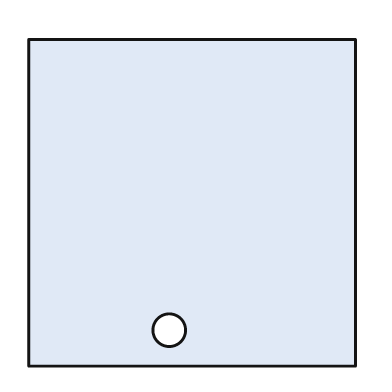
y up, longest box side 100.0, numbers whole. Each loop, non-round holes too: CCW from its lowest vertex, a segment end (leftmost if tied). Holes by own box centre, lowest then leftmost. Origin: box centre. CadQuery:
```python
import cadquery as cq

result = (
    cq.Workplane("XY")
    .moveTo(-50.0, -50.0)
    .lineTo(50.0, -50.0)
    .lineTo(50.0, 50.0)
    .lineTo(-50.0, 50.0)
    .close()
    .moveTo(-7.0, -39.0)
    .circle(5.0)
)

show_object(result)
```